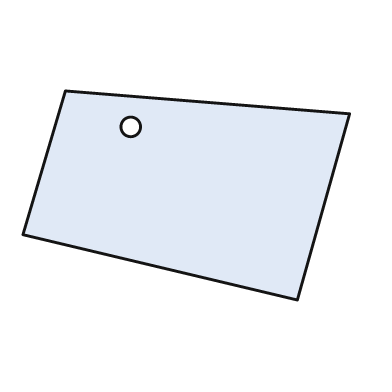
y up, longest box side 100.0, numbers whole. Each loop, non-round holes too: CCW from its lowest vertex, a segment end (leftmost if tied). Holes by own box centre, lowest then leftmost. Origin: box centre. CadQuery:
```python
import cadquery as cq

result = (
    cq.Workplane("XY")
    .moveTo(34.0, -32.0)
    .lineTo(50.0, 25.0)
    .lineTo(-37.0, 32.0)
    .lineTo(-50.0, -12.0)
    .close()
    .moveTo(-17.0, 21.0)
    .circle(3.0)
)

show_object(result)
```